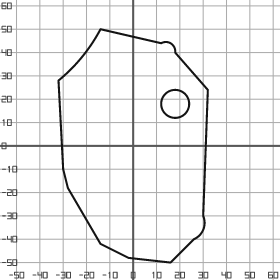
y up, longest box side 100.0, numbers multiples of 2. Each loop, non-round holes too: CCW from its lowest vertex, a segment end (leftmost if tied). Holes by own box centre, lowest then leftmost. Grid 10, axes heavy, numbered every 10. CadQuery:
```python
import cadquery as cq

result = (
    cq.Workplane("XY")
    .moveTo(16.0, -50.0)
    .lineTo(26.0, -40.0)
    .threePointArc((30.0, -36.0), (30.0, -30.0))
    .lineTo(32.0, 24.0)
    .lineTo(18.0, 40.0)
    .threePointArc((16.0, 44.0), (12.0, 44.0))
    .lineTo(-14.0, 50.0)
    .threePointArc((-22.0, 38.0), (-32.0, 28.0))
    .lineTo(-30.0, -10.0)
    .lineTo(-28.0, -18.0)
    .lineTo(-14.0, -42.0)
    .lineTo(-2.0, -48.0)
    .close()
    .moveTo(18.0, 18.0)
    .circle(6.0)
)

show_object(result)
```